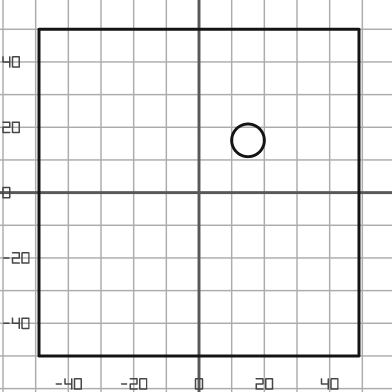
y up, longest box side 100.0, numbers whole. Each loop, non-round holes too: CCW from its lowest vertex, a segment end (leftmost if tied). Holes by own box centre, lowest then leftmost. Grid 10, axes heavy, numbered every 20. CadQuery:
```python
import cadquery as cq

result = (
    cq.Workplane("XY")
    .moveTo(-49.0, -50.0)
    .lineTo(49.0, -50.0)
    .lineTo(49.0, 50.0)
    .lineTo(-49.0, 50.0)
    .close()
    .moveTo(15.0, 16.0)
    .circle(5.0)
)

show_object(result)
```